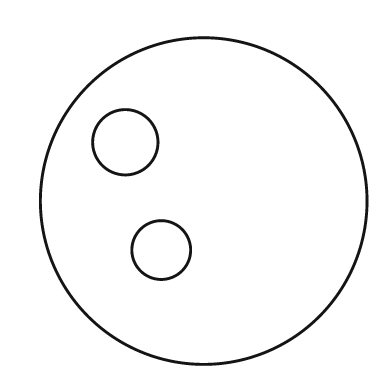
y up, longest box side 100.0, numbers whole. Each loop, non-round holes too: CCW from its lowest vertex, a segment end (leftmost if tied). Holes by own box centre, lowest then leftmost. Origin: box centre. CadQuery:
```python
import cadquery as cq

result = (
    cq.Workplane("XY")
    .moveTo(0.0, 0.0)
    .circle(50.0)
    .moveTo(-13.0, -15.0)
    .circle(9.0)
    .moveTo(-24.0, 18.0)
    .circle(10.0)
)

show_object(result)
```